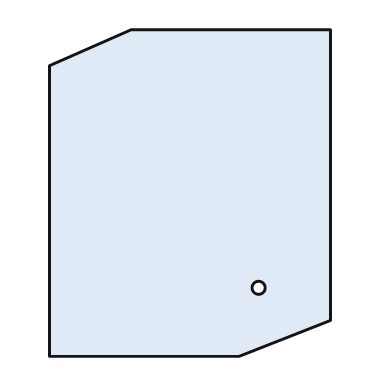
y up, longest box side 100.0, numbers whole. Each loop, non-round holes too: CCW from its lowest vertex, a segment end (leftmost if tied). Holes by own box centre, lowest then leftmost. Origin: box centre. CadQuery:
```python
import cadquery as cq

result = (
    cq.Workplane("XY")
    .moveTo(-43.0, -50.0)
    .lineTo(15.0, -50.0)
    .lineTo(43.0, -39.0)
    .lineTo(43.0, 50.0)
    .lineTo(-18.0, 50.0)
    .lineTo(-43.0, 39.0)
    .close()
    .moveTo(21.0, -29.0)
    .circle(2.0)
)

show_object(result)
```